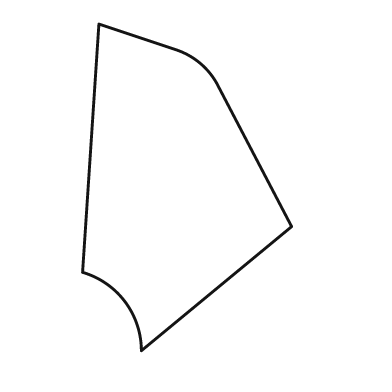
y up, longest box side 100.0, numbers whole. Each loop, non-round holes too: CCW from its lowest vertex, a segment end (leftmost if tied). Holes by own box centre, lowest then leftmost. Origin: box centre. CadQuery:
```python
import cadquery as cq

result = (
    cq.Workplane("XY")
    .moveTo(-14.0, -50.0)
    .lineTo(32.0, -12.0)
    .lineTo(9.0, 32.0)
    .threePointArc((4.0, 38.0), (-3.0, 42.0))
    .lineTo(-27.0, 50.0)
    .lineTo(-32.0, -26.0)
    .threePointArc((-19.0, -35.0), (-14.0, -50.0))
    .close()
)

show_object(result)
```